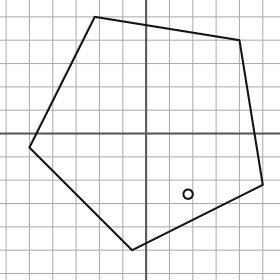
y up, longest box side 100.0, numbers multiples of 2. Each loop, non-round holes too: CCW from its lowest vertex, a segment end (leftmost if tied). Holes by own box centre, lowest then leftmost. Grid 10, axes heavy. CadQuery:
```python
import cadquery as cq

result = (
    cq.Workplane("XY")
    .moveTo(-6.0, -50.0)
    .lineTo(50.0, -22.0)
    .lineTo(40.0, 40.0)
    .lineTo(-22.0, 50.0)
    .lineTo(-50.0, -6.0)
    .close()
    .moveTo(18.0, -26.0)
    .circle(2.0)
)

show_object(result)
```